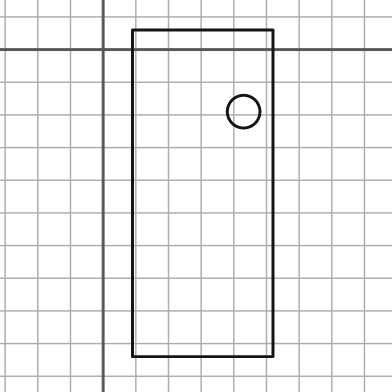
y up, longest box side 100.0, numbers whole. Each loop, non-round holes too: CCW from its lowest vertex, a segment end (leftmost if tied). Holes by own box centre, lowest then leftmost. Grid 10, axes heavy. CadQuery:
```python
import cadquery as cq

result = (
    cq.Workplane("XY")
    .moveTo(9.0, -94.0)
    .lineTo(52.0, -94.0)
    .lineTo(52.0, 6.0)
    .lineTo(9.0, 6.0)
    .close()
    .moveTo(43.0, -19.0)
    .circle(5.0)
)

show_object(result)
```